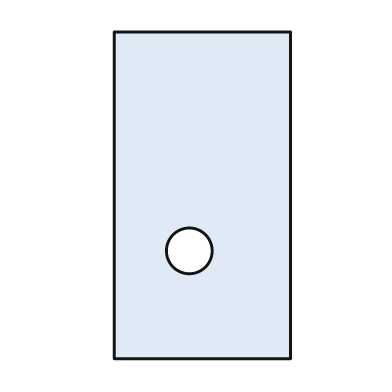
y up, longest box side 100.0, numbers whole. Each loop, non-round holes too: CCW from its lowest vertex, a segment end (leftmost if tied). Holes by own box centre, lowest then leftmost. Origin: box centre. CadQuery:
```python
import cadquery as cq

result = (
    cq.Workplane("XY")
    .moveTo(-27.0, -50.0)
    .lineTo(27.0, -50.0)
    .lineTo(27.0, 50.0)
    .lineTo(-27.0, 50.0)
    .close()
    .moveTo(-4.0, -17.0)
    .circle(7.0)
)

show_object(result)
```